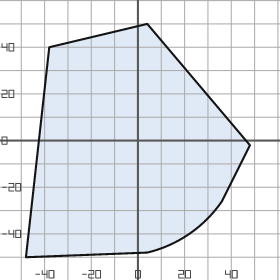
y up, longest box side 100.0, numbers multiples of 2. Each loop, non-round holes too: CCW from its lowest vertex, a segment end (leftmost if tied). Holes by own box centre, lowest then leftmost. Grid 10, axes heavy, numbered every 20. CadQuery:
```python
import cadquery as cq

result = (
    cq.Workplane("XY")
    .moveTo(-48.0, -50.0)
    .lineTo(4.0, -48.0)
    .threePointArc((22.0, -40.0), (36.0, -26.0))
    .lineTo(48.0, -2.0)
    .lineTo(4.0, 50.0)
    .lineTo(-38.0, 40.0)
    .close()
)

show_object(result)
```